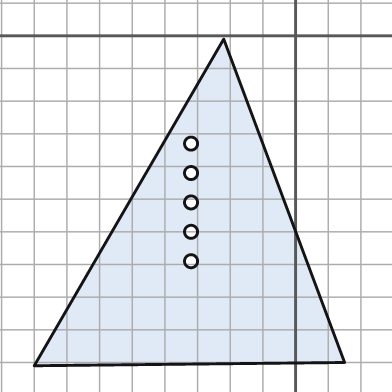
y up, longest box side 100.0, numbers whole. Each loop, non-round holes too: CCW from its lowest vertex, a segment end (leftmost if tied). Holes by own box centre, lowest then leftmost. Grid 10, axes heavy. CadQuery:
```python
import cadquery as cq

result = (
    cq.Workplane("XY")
    .moveTo(-80.0, -101.0)
    .lineTo(15.0, -100.0)
    .lineTo(-22.0, -1.0)
    .close()
    .moveTo(-32.0, -69.0)
    .circle(2.0)
    .moveTo(-32.0, -60.0)
    .circle(2.0)
    .moveTo(-32.0, -51.0)
    .circle(2.0)
    .moveTo(-32.0, -42.0)
    .circle(2.0)
    .moveTo(-32.0, -33.0)
    .circle(2.0)
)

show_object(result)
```